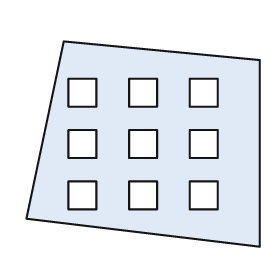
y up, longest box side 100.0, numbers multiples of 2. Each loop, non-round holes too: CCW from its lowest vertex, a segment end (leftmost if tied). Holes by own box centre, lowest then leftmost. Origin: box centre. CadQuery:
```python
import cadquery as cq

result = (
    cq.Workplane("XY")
    .moveTo(50.0, -44.0)
    .lineTo(50.0, 36.0)
    .lineTo(-34.0, 44.0)
    .lineTo(-50.0, -32.0)
    .close()
    .moveTo(-32.0, -28.0)
    .lineTo(-20.0, -28.0)
    .lineTo(-20.0, -16.0)
    .lineTo(-32.0, -16.0)
    .close()
    .moveTo(-6.0, -28.0)
    .lineTo(6.0, -28.0)
    .lineTo(6.0, -16.0)
    .lineTo(-6.0, -16.0)
    .close()
    .moveTo(20.0, -28.0)
    .lineTo(32.0, -28.0)
    .lineTo(32.0, -16.0)
    .lineTo(20.0, -16.0)
    .close()
    .moveTo(-32.0, -6.0)
    .lineTo(-20.0, -6.0)
    .lineTo(-20.0, 6.0)
    .lineTo(-32.0, 6.0)
    .close()
    .moveTo(-6.0, -6.0)
    .lineTo(6.0, -6.0)
    .lineTo(6.0, 6.0)
    .lineTo(-6.0, 6.0)
    .close()
    .moveTo(20.0, -6.0)
    .lineTo(32.0, -6.0)
    .lineTo(32.0, 6.0)
    .lineTo(20.0, 6.0)
    .close()
    .moveTo(-32.0, 16.0)
    .lineTo(-20.0, 16.0)
    .lineTo(-20.0, 28.0)
    .lineTo(-32.0, 28.0)
    .close()
    .moveTo(-6.0, 16.0)
    .lineTo(6.0, 16.0)
    .lineTo(6.0, 28.0)
    .lineTo(-6.0, 28.0)
    .close()
    .moveTo(20.0, 16.0)
    .lineTo(32.0, 16.0)
    .lineTo(32.0, 28.0)
    .lineTo(20.0, 28.0)
    .close()
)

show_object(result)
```